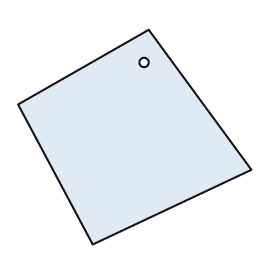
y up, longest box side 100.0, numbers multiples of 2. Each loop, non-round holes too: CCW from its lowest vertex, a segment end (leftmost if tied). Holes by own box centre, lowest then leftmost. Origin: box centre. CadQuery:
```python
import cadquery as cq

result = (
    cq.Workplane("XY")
    .moveTo(-18.0, -46.0)
    .lineTo(50.0, -14.0)
    .lineTo(6.0, 46.0)
    .lineTo(-50.0, 14.0)
    .close()
    .moveTo(4.0, 32.0)
    .circle(2.0)
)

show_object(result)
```